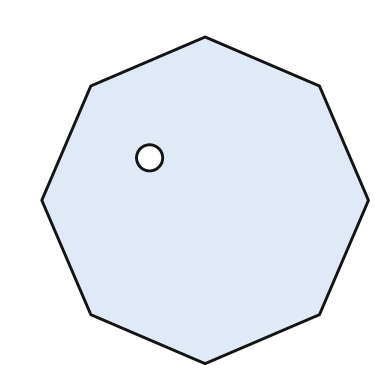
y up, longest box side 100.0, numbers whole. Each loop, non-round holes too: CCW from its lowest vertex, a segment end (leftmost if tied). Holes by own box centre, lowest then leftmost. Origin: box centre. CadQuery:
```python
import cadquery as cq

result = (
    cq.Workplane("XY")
    .moveTo(0.0, -50.0)
    .lineTo(35.0, -35.0)
    .lineTo(50.0, 0.0)
    .lineTo(35.0, 35.0)
    .lineTo(0.0, 50.0)
    .lineTo(-35.0, 35.0)
    .lineTo(-50.0, 0.0)
    .lineTo(-35.0, -35.0)
    .close()
    .moveTo(-17.0, 13.0)
    .circle(4.0)
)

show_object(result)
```